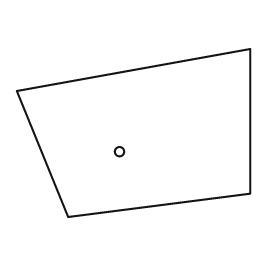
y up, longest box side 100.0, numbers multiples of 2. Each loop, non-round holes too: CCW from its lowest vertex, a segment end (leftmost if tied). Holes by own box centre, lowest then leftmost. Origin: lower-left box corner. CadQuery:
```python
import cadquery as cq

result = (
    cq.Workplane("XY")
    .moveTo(22.0, 0.0)
    .lineTo(100.0, 10.0)
    .lineTo(100.0, 72.0)
    .lineTo(0.0, 54.0)
    .close()
    .moveTo(44.0, 28.0)
    .circle(2.0)
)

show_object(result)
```